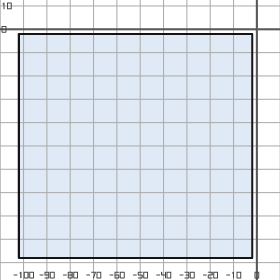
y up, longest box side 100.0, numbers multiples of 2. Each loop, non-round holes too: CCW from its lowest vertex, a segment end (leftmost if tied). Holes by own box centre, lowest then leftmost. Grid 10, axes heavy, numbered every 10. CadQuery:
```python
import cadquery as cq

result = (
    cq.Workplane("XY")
    .moveTo(-102.0, -98.0)
    .lineTo(-2.0, -98.0)
    .lineTo(-2.0, -2.0)
    .lineTo(-102.0, -2.0)
    .close()
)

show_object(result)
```